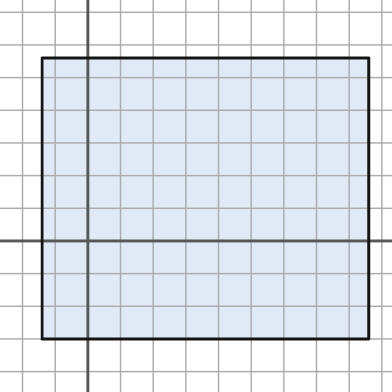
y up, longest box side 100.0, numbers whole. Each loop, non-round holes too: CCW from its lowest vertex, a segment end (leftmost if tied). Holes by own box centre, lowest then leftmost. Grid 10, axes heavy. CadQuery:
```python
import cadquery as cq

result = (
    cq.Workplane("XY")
    .moveTo(-14.0, -30.0)
    .lineTo(86.0, -30.0)
    .lineTo(86.0, 56.0)
    .lineTo(-14.0, 56.0)
    .close()
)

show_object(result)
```